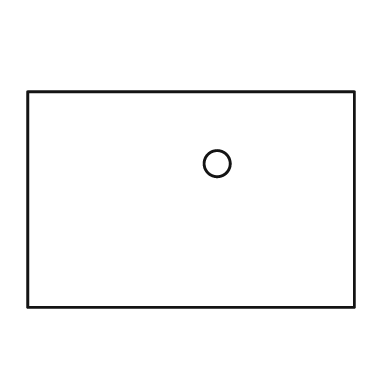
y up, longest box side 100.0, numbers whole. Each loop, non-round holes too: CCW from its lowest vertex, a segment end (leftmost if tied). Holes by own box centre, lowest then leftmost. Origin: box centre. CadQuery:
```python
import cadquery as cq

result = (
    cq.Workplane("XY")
    .moveTo(-50.0, -33.0)
    .lineTo(50.0, -33.0)
    .lineTo(50.0, 33.0)
    .lineTo(-50.0, 33.0)
    .close()
    .moveTo(8.0, 11.0)
    .circle(4.0)
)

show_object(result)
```